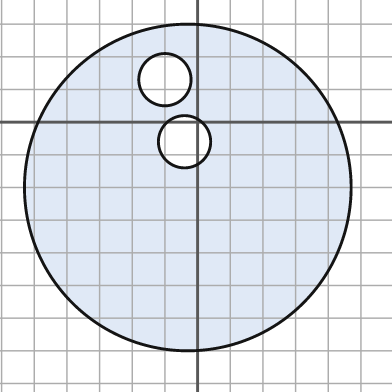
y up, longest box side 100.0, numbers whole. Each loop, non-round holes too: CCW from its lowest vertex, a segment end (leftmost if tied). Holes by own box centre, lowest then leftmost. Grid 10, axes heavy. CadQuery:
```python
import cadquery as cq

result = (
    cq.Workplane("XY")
    .moveTo(-3.0, -20.0)
    .circle(50.0)
    .moveTo(-4.0, -6.0)
    .circle(8.0)
    .moveTo(-10.0, 13.0)
    .circle(8.0)
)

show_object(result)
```